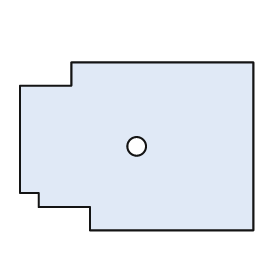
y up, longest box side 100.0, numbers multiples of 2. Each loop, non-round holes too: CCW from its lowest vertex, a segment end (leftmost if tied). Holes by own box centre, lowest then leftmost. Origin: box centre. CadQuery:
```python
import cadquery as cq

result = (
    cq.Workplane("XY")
    .moveTo(-20.0, -36.0)
    .lineTo(50.0, -36.0)
    .lineTo(50.0, 36.0)
    .lineTo(-28.0, 36.0)
    .lineTo(-28.0, 26.0)
    .lineTo(-50.0, 26.0)
    .lineTo(-50.0, -20.0)
    .lineTo(-42.0, -20.0)
    .lineTo(-42.0, -26.0)
    .lineTo(-20.0, -26.0)
    .close()
    .moveTo(0.0, 0.0)
    .circle(4.0)
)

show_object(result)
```